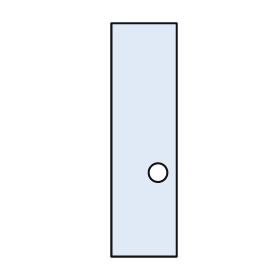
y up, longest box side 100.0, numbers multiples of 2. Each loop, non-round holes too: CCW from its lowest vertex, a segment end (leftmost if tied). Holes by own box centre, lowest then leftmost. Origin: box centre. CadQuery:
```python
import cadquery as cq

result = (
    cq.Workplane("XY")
    .moveTo(-14.0, -50.0)
    .lineTo(14.0, -50.0)
    .lineTo(14.0, 50.0)
    .lineTo(-14.0, 50.0)
    .close()
    .moveTo(6.0, -14.0)
    .circle(4.0)
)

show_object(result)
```